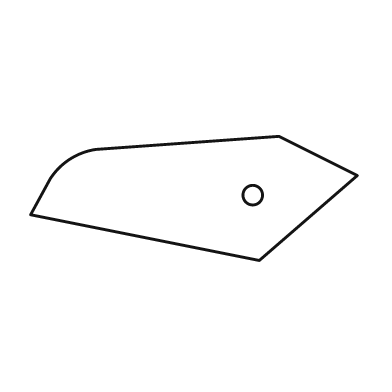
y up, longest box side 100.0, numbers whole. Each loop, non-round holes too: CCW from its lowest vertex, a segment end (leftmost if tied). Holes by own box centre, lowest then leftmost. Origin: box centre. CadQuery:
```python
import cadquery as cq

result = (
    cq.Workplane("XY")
    .moveTo(20.0, -19.0)
    .lineTo(50.0, 7.0)
    .lineTo(26.0, 19.0)
    .lineTo(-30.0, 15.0)
    .threePointArc((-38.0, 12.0), (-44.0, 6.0))
    .lineTo(-50.0, -5.0)
    .close()
    .moveTo(18.0, 1.0)
    .circle(3.0)
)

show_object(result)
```